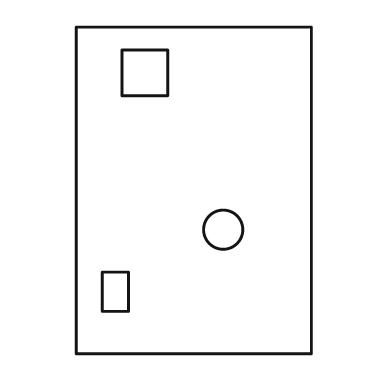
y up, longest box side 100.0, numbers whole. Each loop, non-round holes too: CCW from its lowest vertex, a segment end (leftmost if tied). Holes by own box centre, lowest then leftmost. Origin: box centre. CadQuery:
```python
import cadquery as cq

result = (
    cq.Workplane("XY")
    .moveTo(-36.0, -50.0)
    .lineTo(36.0, -50.0)
    .lineTo(36.0, 50.0)
    .lineTo(-36.0, 50.0)
    .close()
    .moveTo(-28.0, -37.0)
    .lineTo(-20.0, -37.0)
    .lineTo(-20.0, -25.0)
    .lineTo(-28.0, -25.0)
    .close()
    .moveTo(9.0, -12.0)
    .circle(6.0)
    .moveTo(-22.0, 29.0)
    .lineTo(-8.0, 29.0)
    .lineTo(-8.0, 43.0)
    .lineTo(-22.0, 43.0)
    .close()
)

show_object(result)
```